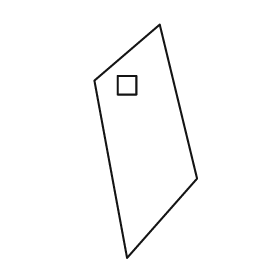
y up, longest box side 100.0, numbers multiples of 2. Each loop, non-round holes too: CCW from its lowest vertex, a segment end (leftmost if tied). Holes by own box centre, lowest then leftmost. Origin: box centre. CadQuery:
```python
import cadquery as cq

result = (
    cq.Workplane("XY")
    .moveTo(-8.0, -50.0)
    .lineTo(22.0, -16.0)
    .lineTo(6.0, 50.0)
    .lineTo(-22.0, 26.0)
    .close()
    .moveTo(-12.0, 20.0)
    .lineTo(-4.0, 20.0)
    .lineTo(-4.0, 28.0)
    .lineTo(-12.0, 28.0)
    .close()
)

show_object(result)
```